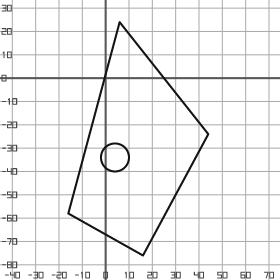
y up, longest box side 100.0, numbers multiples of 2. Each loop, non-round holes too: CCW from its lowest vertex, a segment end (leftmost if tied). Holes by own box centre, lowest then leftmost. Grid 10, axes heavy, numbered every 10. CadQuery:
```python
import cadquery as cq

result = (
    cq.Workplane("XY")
    .moveTo(16.0, -76.0)
    .lineTo(44.0, -24.0)
    .lineTo(6.0, 24.0)
    .lineTo(-16.0, -58.0)
    .close()
    .moveTo(4.0, -34.0)
    .circle(6.0)
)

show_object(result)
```